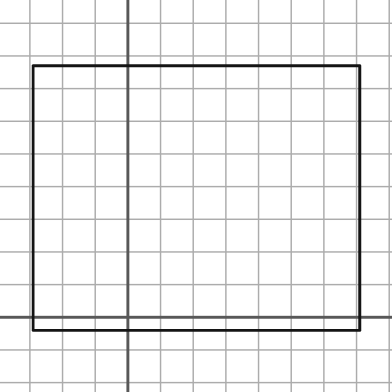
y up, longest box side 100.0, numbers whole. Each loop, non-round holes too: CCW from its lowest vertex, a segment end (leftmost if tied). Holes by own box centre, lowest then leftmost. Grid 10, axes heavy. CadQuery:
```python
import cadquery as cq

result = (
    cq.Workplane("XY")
    .moveTo(-29.0, -4.0)
    .lineTo(71.0, -4.0)
    .lineTo(71.0, 77.0)
    .lineTo(-29.0, 77.0)
    .close()
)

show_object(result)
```